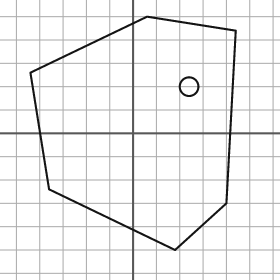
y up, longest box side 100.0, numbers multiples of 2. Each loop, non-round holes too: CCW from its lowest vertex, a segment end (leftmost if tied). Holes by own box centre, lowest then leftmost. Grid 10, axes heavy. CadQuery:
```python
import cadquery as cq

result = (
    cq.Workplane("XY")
    .moveTo(18.0, -50.0)
    .lineTo(40.0, -30.0)
    .lineTo(44.0, 44.0)
    .lineTo(6.0, 50.0)
    .lineTo(-44.0, 26.0)
    .lineTo(-36.0, -24.0)
    .close()
    .moveTo(24.0, 20.0)
    .circle(4.0)
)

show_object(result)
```